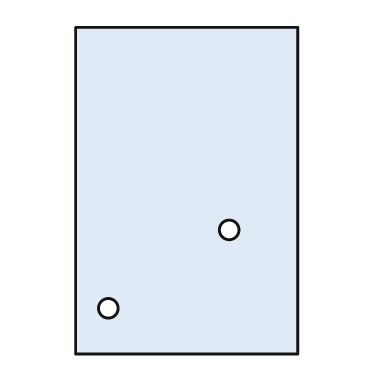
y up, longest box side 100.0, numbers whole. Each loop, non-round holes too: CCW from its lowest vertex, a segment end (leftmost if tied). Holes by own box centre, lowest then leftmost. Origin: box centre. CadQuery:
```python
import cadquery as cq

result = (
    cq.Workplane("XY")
    .moveTo(-34.0, -50.0)
    .lineTo(34.0, -50.0)
    .lineTo(34.0, 50.0)
    .lineTo(-34.0, 50.0)
    .close()
    .moveTo(-24.0, -36.0)
    .circle(3.0)
    .moveTo(13.0, -12.0)
    .circle(3.0)
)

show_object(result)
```